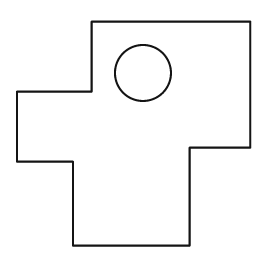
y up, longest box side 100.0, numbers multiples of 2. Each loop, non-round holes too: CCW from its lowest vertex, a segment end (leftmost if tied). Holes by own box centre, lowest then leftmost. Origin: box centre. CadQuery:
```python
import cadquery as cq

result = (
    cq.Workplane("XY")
    .moveTo(-26.0, -48.0)
    .lineTo(24.0, -48.0)
    .lineTo(24.0, -6.0)
    .lineTo(50.0, -6.0)
    .lineTo(50.0, 48.0)
    .lineTo(-18.0, 48.0)
    .lineTo(-18.0, 18.0)
    .lineTo(-50.0, 18.0)
    .lineTo(-50.0, -12.0)
    .lineTo(-26.0, -12.0)
    .close()
    .moveTo(4.0, 26.0)
    .circle(12.0)
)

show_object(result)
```